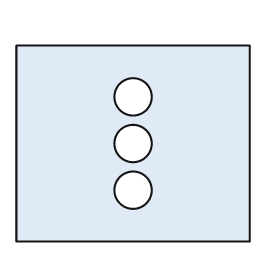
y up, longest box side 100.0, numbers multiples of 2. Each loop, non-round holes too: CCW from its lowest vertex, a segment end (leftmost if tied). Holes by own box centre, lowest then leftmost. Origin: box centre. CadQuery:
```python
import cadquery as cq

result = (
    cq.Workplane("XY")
    .moveTo(-50.0, -42.0)
    .lineTo(50.0, -42.0)
    .lineTo(50.0, 42.0)
    .lineTo(-50.0, 42.0)
    .close()
    .moveTo(0.0, -20.0)
    .circle(8.0)
    .moveTo(0.0, 0.0)
    .circle(8.0)
    .moveTo(0.0, 20.0)
    .circle(8.0)
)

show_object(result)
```